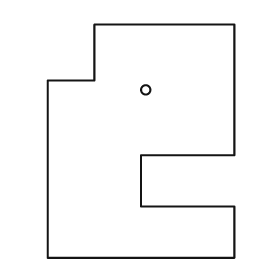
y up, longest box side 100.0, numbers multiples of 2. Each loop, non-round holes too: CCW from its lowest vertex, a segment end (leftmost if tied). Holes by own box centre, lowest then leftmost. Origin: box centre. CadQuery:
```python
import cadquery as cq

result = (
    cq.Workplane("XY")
    .moveTo(-40.0, -50.0)
    .lineTo(40.0, -50.0)
    .lineTo(40.0, -28.0)
    .lineTo(0.0, -28.0)
    .lineTo(0.0, -6.0)
    .lineTo(40.0, -6.0)
    .lineTo(40.0, 50.0)
    .lineTo(-20.0, 50.0)
    .lineTo(-20.0, 26.0)
    .lineTo(-40.0, 26.0)
    .close()
    .moveTo(2.0, 22.0)
    .circle(2.0)
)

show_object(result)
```